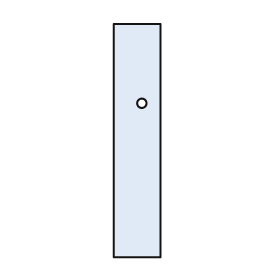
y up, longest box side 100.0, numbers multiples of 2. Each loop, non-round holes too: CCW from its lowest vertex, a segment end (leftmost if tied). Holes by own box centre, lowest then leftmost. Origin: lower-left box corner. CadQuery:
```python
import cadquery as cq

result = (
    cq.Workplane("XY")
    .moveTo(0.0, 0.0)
    .lineTo(20.0, 0.0)
    .lineTo(20.0, 100.0)
    .lineTo(0.0, 100.0)
    .close()
    .moveTo(12.0, 66.0)
    .circle(2.0)
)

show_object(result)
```